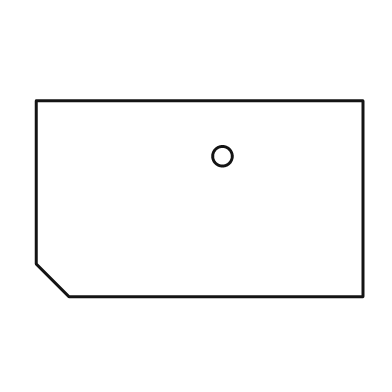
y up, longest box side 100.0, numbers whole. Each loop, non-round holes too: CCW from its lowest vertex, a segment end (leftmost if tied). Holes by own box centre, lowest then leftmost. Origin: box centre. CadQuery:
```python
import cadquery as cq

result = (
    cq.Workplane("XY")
    .moveTo(-40.0, -30.0)
    .lineTo(50.0, -30.0)
    .lineTo(50.0, 30.0)
    .lineTo(-50.0, 30.0)
    .lineTo(-50.0, -20.0)
    .close()
    .moveTo(7.0, 13.0)
    .circle(3.0)
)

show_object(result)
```